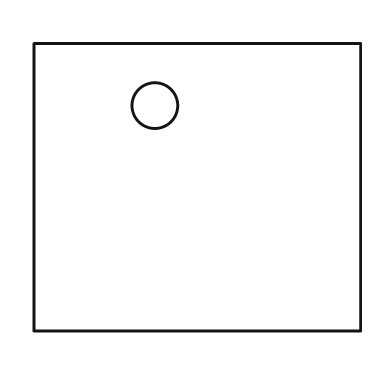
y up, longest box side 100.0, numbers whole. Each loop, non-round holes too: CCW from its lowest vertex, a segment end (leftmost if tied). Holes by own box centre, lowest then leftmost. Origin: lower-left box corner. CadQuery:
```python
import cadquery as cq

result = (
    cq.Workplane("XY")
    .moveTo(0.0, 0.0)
    .lineTo(100.0, 0.0)
    .lineTo(100.0, 88.0)
    .lineTo(0.0, 88.0)
    .close()
    .moveTo(37.0, 69.0)
    .circle(7.0)
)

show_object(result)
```